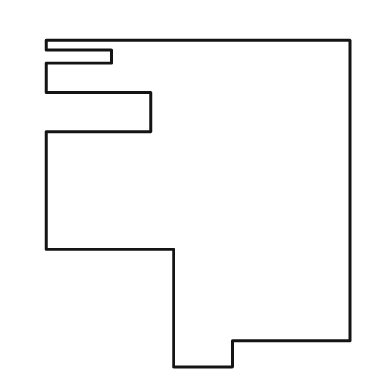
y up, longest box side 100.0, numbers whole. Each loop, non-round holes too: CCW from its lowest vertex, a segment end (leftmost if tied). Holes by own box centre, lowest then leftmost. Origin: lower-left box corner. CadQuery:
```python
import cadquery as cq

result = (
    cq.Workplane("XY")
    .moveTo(39.0, 0.0)
    .lineTo(57.0, 0.0)
    .lineTo(57.0, 8.0)
    .lineTo(93.0, 8.0)
    .lineTo(93.0, 100.0)
    .lineTo(0.0, 100.0)
    .lineTo(0.0, 97.0)
    .lineTo(20.0, 97.0)
    .lineTo(20.0, 93.0)
    .lineTo(0.0, 93.0)
    .lineTo(0.0, 84.0)
    .lineTo(32.0, 84.0)
    .lineTo(32.0, 72.0)
    .lineTo(0.0, 72.0)
    .lineTo(0.0, 36.0)
    .lineTo(39.0, 36.0)
    .close()
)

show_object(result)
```